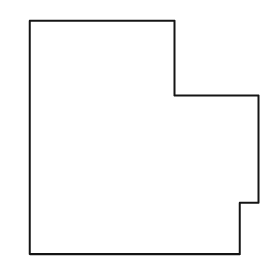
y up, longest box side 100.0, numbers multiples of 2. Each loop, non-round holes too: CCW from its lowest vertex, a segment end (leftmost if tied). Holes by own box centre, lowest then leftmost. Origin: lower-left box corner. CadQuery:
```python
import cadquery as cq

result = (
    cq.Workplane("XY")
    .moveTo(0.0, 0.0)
    .lineTo(90.0, 0.0)
    .lineTo(90.0, 22.0)
    .lineTo(98.0, 22.0)
    .lineTo(98.0, 68.0)
    .lineTo(62.0, 68.0)
    .lineTo(62.0, 100.0)
    .lineTo(0.0, 100.0)
    .close()
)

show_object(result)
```